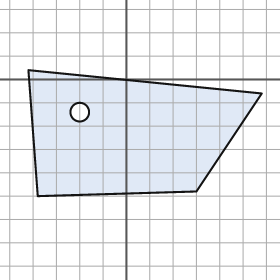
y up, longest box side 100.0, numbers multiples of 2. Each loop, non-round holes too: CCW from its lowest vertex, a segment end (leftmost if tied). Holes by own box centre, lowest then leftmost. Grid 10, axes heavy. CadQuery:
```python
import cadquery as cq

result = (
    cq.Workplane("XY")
    .moveTo(-38.0, -50.0)
    .lineTo(30.0, -48.0)
    .lineTo(58.0, -6.0)
    .lineTo(-42.0, 4.0)
    .close()
    .moveTo(-20.0, -14.0)
    .circle(4.0)
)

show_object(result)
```